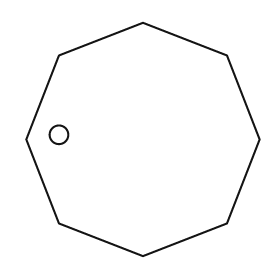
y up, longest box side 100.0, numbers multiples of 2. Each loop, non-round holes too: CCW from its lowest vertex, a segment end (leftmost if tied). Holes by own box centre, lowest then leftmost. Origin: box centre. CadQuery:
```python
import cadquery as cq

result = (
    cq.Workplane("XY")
    .moveTo(0.0, -50.0)
    .lineTo(36.0, -36.0)
    .lineTo(50.0, 0.0)
    .lineTo(36.0, 36.0)
    .lineTo(0.0, 50.0)
    .lineTo(-36.0, 36.0)
    .lineTo(-50.0, 0.0)
    .lineTo(-36.0, -36.0)
    .close()
    .moveTo(-36.0, 2.0)
    .circle(4.0)
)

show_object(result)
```